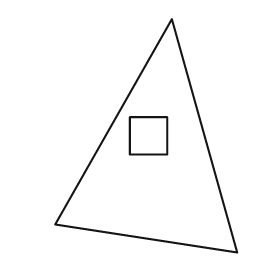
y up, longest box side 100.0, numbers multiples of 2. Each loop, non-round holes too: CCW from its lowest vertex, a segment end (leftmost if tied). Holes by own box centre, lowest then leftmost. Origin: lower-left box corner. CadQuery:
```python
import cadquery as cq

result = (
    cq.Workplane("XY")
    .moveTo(78.0, 0.0)
    .lineTo(50.0, 100.0)
    .lineTo(0.0, 12.0)
    .close()
    .moveTo(32.0, 42.0)
    .lineTo(48.0, 42.0)
    .lineTo(48.0, 58.0)
    .lineTo(32.0, 58.0)
    .close()
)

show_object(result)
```